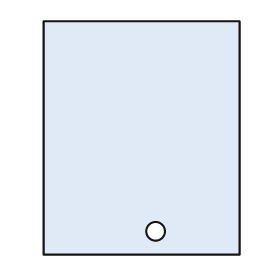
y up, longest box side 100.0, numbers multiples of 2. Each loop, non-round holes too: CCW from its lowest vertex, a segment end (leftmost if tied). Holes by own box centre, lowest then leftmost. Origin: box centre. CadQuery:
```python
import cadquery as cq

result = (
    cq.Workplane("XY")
    .moveTo(-42.0, -50.0)
    .lineTo(42.0, -50.0)
    .lineTo(42.0, 50.0)
    .lineTo(-42.0, 50.0)
    .close()
    .moveTo(6.0, -40.0)
    .circle(4.0)
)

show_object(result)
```